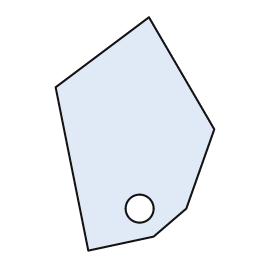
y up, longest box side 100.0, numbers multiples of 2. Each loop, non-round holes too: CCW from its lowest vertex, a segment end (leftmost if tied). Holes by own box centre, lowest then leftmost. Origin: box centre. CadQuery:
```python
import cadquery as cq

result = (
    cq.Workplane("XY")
    .moveTo(-20.0, -50.0)
    .lineTo(8.0, -44.0)
    .lineTo(22.0, -32.0)
    .lineTo(34.0, 2.0)
    .lineTo(6.0, 50.0)
    .lineTo(-34.0, 20.0)
    .close()
    .moveTo(2.0, -32.0)
    .circle(6.0)
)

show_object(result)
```